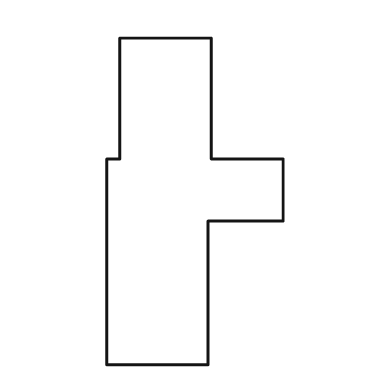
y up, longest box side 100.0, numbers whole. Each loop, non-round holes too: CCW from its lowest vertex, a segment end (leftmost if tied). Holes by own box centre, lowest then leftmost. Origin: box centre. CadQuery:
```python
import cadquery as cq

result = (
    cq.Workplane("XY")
    .moveTo(-27.0, -50.0)
    .lineTo(4.0, -50.0)
    .lineTo(4.0, -6.0)
    .lineTo(27.0, -6.0)
    .lineTo(27.0, 13.0)
    .lineTo(5.0, 13.0)
    .lineTo(5.0, 50.0)
    .lineTo(-23.0, 50.0)
    .lineTo(-23.0, 13.0)
    .lineTo(-27.0, 13.0)
    .close()
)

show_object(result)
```